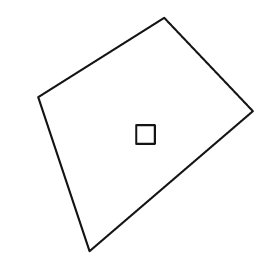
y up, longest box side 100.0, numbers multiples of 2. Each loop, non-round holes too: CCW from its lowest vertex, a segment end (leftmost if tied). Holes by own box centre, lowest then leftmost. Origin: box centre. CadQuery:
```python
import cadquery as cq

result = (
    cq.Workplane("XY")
    .moveTo(-24.0, -50.0)
    .lineTo(46.0, 10.0)
    .lineTo(8.0, 50.0)
    .lineTo(-46.0, 16.0)
    .close()
    .moveTo(-4.0, -4.0)
    .lineTo(4.0, -4.0)
    .lineTo(4.0, 4.0)
    .lineTo(-4.0, 4.0)
    .close()
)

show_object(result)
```